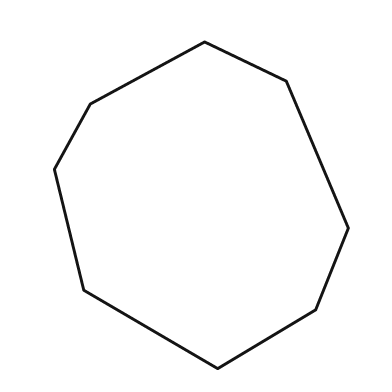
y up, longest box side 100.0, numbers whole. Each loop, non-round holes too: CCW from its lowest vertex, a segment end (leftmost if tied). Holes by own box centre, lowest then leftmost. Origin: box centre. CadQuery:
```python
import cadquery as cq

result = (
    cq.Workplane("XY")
    .moveTo(5.0, -50.0)
    .lineTo(35.0, -32.0)
    .lineTo(45.0, -7.0)
    .lineTo(26.0, 38.0)
    .lineTo(1.0, 50.0)
    .lineTo(-34.0, 31.0)
    .lineTo(-45.0, 11.0)
    .lineTo(-36.0, -26.0)
    .close()
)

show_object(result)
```